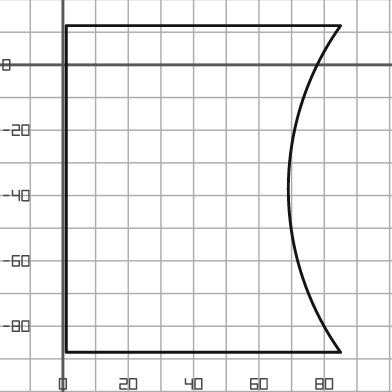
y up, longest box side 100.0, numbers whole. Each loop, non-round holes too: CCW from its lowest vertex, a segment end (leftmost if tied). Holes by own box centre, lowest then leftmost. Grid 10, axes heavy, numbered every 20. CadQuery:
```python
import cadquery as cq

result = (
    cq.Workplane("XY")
    .moveTo(1.0, -88.0)
    .lineTo(85.0, -88.0)
    .threePointArc((69.0, -38.0), (85.0, 12.0))
    .lineTo(1.0, 12.0)
    .close()
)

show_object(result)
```